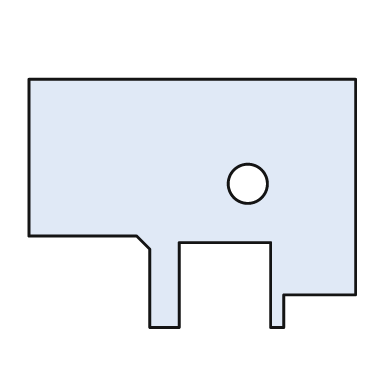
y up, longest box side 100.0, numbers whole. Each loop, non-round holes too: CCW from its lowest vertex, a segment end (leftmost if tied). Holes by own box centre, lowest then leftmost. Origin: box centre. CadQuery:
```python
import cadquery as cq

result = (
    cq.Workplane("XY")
    .moveTo(-13.0, -38.0)
    .lineTo(-4.0, -38.0)
    .lineTo(-4.0, -12.0)
    .lineTo(24.0, -12.0)
    .lineTo(24.0, -38.0)
    .lineTo(28.0, -38.0)
    .lineTo(28.0, -28.0)
    .lineTo(50.0, -28.0)
    .lineTo(50.0, 38.0)
    .lineTo(-50.0, 38.0)
    .lineTo(-50.0, -10.0)
    .lineTo(-17.0, -10.0)
    .lineTo(-13.0, -14.0)
    .close()
    .moveTo(17.0, 6.0)
    .circle(6.0)
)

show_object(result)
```